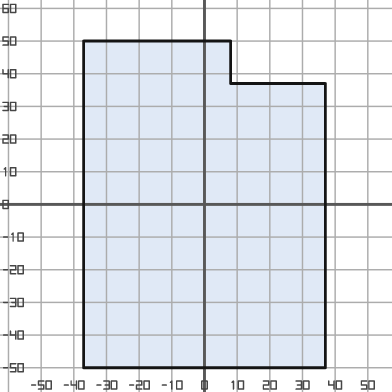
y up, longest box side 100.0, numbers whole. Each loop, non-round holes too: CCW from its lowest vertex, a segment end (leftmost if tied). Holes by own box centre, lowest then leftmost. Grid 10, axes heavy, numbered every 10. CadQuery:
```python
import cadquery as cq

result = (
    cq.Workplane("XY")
    .moveTo(-37.0, -50.0)
    .lineTo(37.0, -50.0)
    .lineTo(37.0, 37.0)
    .lineTo(8.0, 37.0)
    .lineTo(8.0, 50.0)
    .lineTo(-37.0, 50.0)
    .close()
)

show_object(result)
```